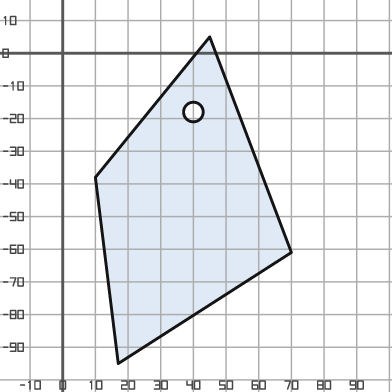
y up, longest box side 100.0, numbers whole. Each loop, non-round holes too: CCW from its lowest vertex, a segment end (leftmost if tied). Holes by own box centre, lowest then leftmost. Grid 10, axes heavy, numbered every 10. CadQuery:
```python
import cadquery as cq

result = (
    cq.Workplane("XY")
    .moveTo(17.0, -95.0)
    .lineTo(70.0, -61.0)
    .lineTo(45.0, 5.0)
    .lineTo(10.0, -38.0)
    .close()
    .moveTo(40.0, -18.0)
    .circle(3.0)
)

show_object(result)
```